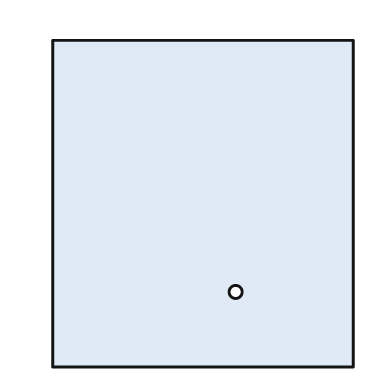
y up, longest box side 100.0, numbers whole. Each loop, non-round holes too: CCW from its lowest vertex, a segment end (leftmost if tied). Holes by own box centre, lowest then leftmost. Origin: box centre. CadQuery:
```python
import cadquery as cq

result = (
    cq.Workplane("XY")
    .moveTo(-46.0, -50.0)
    .lineTo(46.0, -50.0)
    .lineTo(46.0, 50.0)
    .lineTo(-46.0, 50.0)
    .close()
    .moveTo(10.0, -27.0)
    .circle(2.0)
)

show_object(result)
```